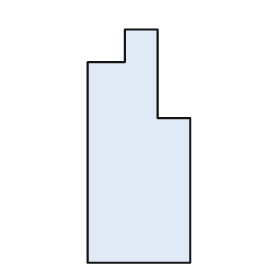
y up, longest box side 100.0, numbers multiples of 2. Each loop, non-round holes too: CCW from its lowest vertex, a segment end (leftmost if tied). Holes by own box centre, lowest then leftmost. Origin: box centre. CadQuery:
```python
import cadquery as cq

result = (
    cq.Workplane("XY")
    .moveTo(-22.0, -50.0)
    .lineTo(22.0, -50.0)
    .lineTo(22.0, 12.0)
    .lineTo(8.0, 12.0)
    .lineTo(8.0, 50.0)
    .lineTo(-6.0, 50.0)
    .lineTo(-6.0, 36.0)
    .lineTo(-22.0, 36.0)
    .close()
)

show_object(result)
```